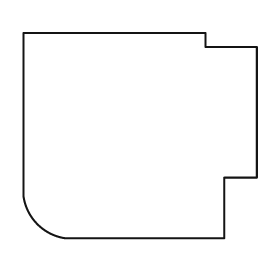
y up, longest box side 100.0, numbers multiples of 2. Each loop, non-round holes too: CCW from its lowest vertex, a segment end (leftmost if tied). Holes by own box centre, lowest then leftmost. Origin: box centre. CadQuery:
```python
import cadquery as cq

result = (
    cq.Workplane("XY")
    .moveTo(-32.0, -44.0)
    .lineTo(36.0, -44.0)
    .lineTo(36.0, -18.0)
    .lineTo(50.0, -18.0)
    .lineTo(50.0, 38.0)
    .lineTo(28.0, 38.0)
    .lineTo(28.0, 44.0)
    .lineTo(-50.0, 44.0)
    .lineTo(-50.0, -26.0)
    .threePointArc((-44.0, -38.0), (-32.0, -44.0))
    .close()
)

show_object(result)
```